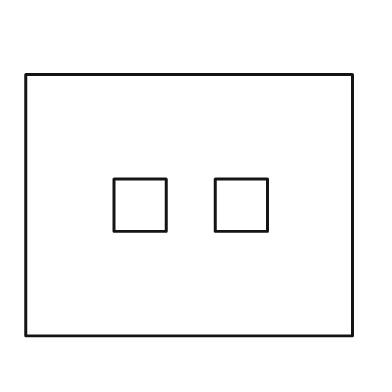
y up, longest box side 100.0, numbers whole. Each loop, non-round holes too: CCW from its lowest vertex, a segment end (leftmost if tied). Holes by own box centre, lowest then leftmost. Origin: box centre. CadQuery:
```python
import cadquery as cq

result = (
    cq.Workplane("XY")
    .moveTo(-50.0, -40.0)
    .lineTo(50.0, -40.0)
    .lineTo(50.0, 40.0)
    .lineTo(-50.0, 40.0)
    .close()
    .moveTo(-23.0, -8.0)
    .lineTo(-7.0, -8.0)
    .lineTo(-7.0, 8.0)
    .lineTo(-23.0, 8.0)
    .close()
    .moveTo(8.0, -8.0)
    .lineTo(24.0, -8.0)
    .lineTo(24.0, 8.0)
    .lineTo(8.0, 8.0)
    .close()
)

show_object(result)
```